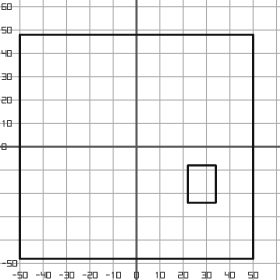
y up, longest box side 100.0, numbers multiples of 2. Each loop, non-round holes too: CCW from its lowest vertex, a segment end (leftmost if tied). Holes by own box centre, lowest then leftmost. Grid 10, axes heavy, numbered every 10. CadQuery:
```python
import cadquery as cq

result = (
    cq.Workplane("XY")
    .moveTo(-50.0, -48.0)
    .lineTo(50.0, -48.0)
    .lineTo(50.0, 48.0)
    .lineTo(-50.0, 48.0)
    .close()
    .moveTo(22.0, -24.0)
    .lineTo(34.0, -24.0)
    .lineTo(34.0, -8.0)
    .lineTo(22.0, -8.0)
    .close()
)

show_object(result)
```